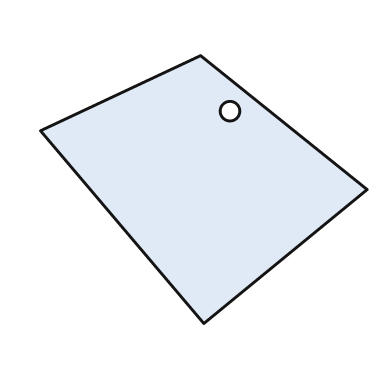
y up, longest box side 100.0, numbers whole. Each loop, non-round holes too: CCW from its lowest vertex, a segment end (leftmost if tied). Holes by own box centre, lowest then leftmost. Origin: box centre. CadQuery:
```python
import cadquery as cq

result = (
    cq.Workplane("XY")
    .moveTo(0.0, -41.0)
    .lineTo(50.0, 0.0)
    .lineTo(-1.0, 41.0)
    .lineTo(-50.0, 18.0)
    .close()
    .moveTo(8.0, 24.0)
    .circle(3.0)
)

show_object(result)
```